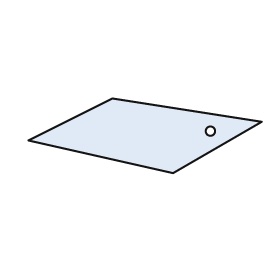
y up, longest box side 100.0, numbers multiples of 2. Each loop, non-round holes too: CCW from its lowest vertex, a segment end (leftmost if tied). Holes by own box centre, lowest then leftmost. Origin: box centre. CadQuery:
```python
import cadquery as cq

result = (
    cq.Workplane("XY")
    .moveTo(12.0, -16.0)
    .lineTo(50.0, 6.0)
    .lineTo(-14.0, 16.0)
    .lineTo(-50.0, -2.0)
    .close()
    .moveTo(28.0, 2.0)
    .circle(2.0)
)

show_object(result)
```